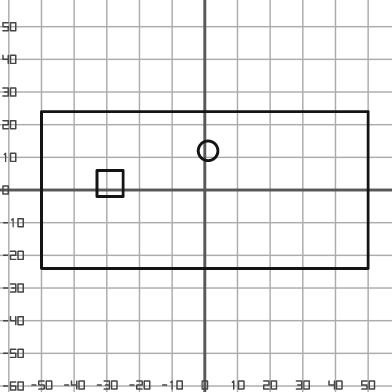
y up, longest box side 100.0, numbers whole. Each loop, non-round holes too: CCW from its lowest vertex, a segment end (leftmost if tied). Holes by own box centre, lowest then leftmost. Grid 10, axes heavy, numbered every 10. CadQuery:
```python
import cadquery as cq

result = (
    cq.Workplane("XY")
    .moveTo(-50.0, -24.0)
    .lineTo(50.0, -24.0)
    .lineTo(50.0, 24.0)
    .lineTo(-50.0, 24.0)
    .close()
    .moveTo(-33.0, -2.0)
    .lineTo(-25.0, -2.0)
    .lineTo(-25.0, 6.0)
    .lineTo(-33.0, 6.0)
    .close()
    .moveTo(1.0, 12.0)
    .circle(3.0)
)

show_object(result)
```